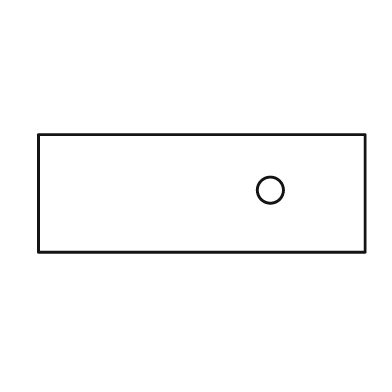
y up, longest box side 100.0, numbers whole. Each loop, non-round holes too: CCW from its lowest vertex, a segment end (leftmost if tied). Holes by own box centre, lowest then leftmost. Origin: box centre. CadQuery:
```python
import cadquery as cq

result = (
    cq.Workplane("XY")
    .moveTo(-50.0, -18.0)
    .lineTo(50.0, -18.0)
    .lineTo(50.0, 18.0)
    .lineTo(-50.0, 18.0)
    .close()
    .moveTo(21.0, 1.0)
    .circle(4.0)
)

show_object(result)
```